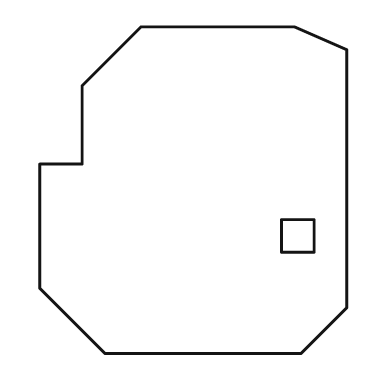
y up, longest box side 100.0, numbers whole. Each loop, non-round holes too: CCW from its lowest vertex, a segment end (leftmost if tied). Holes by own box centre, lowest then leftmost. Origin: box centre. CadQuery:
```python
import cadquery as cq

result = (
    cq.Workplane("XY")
    .moveTo(-27.0, -50.0)
    .lineTo(33.0, -50.0)
    .lineTo(47.0, -36.0)
    .lineTo(47.0, 43.0)
    .lineTo(31.0, 50.0)
    .lineTo(-16.0, 50.0)
    .lineTo(-34.0, 32.0)
    .lineTo(-34.0, 8.0)
    .lineTo(-47.0, 8.0)
    .lineTo(-47.0, -30.0)
    .close()
    .moveTo(27.0, -19.0)
    .lineTo(37.0, -19.0)
    .lineTo(37.0, -9.0)
    .lineTo(27.0, -9.0)
    .close()
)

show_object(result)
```